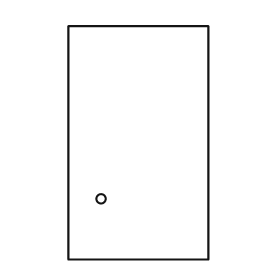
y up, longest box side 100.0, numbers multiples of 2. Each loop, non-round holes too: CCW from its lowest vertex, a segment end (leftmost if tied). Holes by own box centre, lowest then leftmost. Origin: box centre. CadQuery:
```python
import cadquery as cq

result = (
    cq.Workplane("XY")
    .moveTo(-30.0, -50.0)
    .lineTo(30.0, -50.0)
    .lineTo(30.0, 50.0)
    .lineTo(-30.0, 50.0)
    .close()
    .moveTo(-16.0, -24.0)
    .circle(2.0)
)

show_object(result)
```